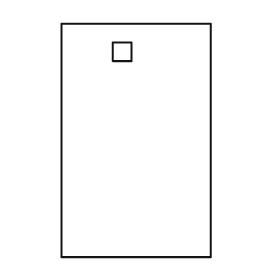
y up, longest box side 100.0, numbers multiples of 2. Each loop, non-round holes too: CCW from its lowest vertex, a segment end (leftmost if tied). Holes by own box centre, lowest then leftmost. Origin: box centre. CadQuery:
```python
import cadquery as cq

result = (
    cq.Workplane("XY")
    .moveTo(-32.0, -50.0)
    .lineTo(32.0, -50.0)
    .lineTo(32.0, 50.0)
    .lineTo(-32.0, 50.0)
    .close()
    .moveTo(-10.0, 34.0)
    .lineTo(-2.0, 34.0)
    .lineTo(-2.0, 42.0)
    .lineTo(-10.0, 42.0)
    .close()
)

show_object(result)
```